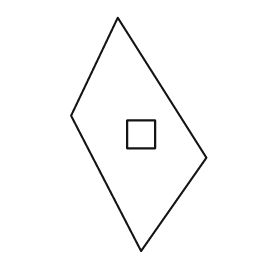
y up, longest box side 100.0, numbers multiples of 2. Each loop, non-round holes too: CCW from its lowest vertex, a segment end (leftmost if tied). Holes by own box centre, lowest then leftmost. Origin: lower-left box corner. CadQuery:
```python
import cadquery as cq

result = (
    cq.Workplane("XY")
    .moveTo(30.0, 0.0)
    .lineTo(58.0, 40.0)
    .lineTo(20.0, 100.0)
    .lineTo(0.0, 58.0)
    .close()
    .moveTo(24.0, 44.0)
    .lineTo(36.0, 44.0)
    .lineTo(36.0, 56.0)
    .lineTo(24.0, 56.0)
    .close()
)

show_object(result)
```